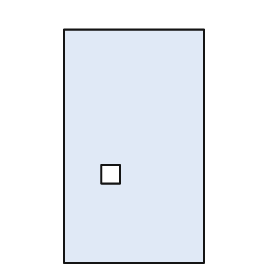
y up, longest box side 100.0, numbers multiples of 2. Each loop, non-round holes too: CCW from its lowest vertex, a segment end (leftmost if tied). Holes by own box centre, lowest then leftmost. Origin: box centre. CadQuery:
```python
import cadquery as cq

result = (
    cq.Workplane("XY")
    .moveTo(-30.0, -50.0)
    .lineTo(30.0, -50.0)
    .lineTo(30.0, 50.0)
    .lineTo(-30.0, 50.0)
    .close()
    .moveTo(-14.0, -16.0)
    .lineTo(-6.0, -16.0)
    .lineTo(-6.0, -8.0)
    .lineTo(-14.0, -8.0)
    .close()
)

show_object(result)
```